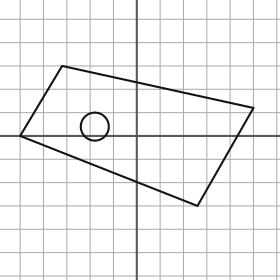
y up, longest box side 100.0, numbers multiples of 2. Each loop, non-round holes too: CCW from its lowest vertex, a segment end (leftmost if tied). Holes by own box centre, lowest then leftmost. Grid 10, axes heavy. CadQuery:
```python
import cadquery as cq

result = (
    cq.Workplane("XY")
    .moveTo(26.0, -30.0)
    .lineTo(50.0, 12.0)
    .lineTo(-32.0, 30.0)
    .lineTo(-50.0, 0.0)
    .close()
    .moveTo(-18.0, 4.0)
    .circle(6.0)
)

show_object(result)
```